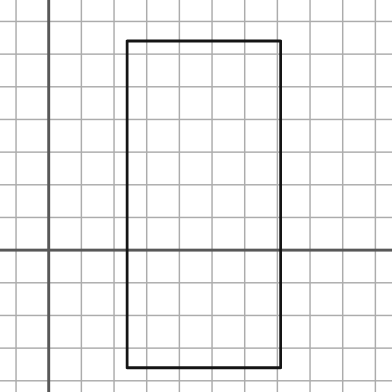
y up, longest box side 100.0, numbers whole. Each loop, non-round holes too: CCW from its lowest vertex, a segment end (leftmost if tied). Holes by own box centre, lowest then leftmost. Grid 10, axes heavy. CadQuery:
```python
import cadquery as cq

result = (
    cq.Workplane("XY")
    .moveTo(24.0, -36.0)
    .lineTo(71.0, -36.0)
    .lineTo(71.0, 64.0)
    .lineTo(24.0, 64.0)
    .close()
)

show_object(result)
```